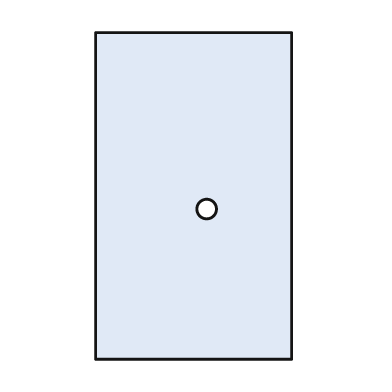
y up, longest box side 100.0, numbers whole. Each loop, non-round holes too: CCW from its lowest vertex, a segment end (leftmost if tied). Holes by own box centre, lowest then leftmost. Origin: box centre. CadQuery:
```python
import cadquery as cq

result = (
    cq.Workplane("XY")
    .moveTo(-30.0, -50.0)
    .lineTo(30.0, -50.0)
    .lineTo(30.0, 50.0)
    .lineTo(-30.0, 50.0)
    .close()
    .moveTo(4.0, -4.0)
    .circle(3.0)
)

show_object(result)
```